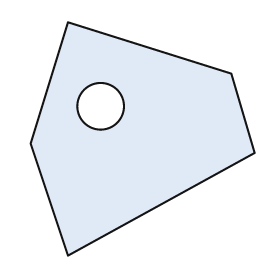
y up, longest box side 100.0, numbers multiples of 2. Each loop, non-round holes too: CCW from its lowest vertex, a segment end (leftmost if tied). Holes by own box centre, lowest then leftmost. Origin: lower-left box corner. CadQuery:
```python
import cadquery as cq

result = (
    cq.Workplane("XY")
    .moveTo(16.0, 0.0)
    .lineTo(96.0, 44.0)
    .lineTo(86.0, 78.0)
    .lineTo(16.0, 100.0)
    .lineTo(0.0, 48.0)
    .close()
    .moveTo(30.0, 64.0)
    .circle(10.0)
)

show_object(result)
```